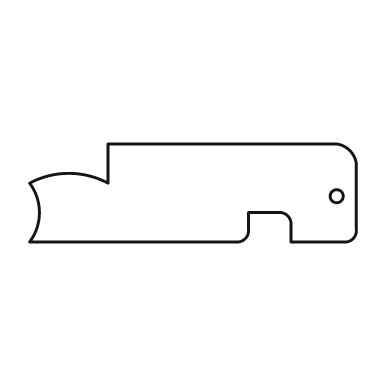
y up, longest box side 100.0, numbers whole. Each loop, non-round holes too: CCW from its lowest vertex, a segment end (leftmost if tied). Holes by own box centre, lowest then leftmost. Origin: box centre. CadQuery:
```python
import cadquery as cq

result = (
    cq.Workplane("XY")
    .moveTo(-50.0, -15.0)
    .lineTo(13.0, -15.0)
    .threePointArc((16.0, -14.0), (17.0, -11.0))
    .lineTo(17.0, -6.0)
    .lineTo(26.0, -6.0)
    .threePointArc((29.0, -7.0), (30.0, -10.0))
    .lineTo(30.0, -15.0)
    .lineTo(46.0, -15.0)
    .threePointArc((49.0, -14.0), (50.0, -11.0))
    .lineTo(50.0, 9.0)
    .threePointArc((48.0, 13.0), (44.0, 15.0))
    .lineTo(-26.0, 15.0)
    .lineTo(-26.0, 3.0)
    .threePointArc((-38.0, 6.0), (-50.0, 3.0))
    .threePointArc((-47.0, -6.0), (-50.0, -15.0))
    .close()
    .moveTo(44.0, -1.0)
    .circle(2.0)
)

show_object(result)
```